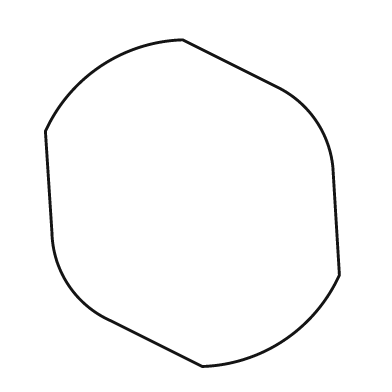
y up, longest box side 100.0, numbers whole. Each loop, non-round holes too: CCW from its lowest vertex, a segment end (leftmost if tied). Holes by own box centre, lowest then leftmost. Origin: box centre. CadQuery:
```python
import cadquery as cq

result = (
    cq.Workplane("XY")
    .moveTo(3.0, -50.0)
    .threePointArc((28.0, -42.0), (45.0, -22.0))
    .lineTo(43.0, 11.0)
    .threePointArc((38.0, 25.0), (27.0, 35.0))
    .lineTo(-3.0, 50.0)
    .threePointArc((-28.0, 42.0), (-45.0, 22.0))
    .lineTo(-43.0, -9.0)
    .threePointArc((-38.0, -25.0), (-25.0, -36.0))
    .close()
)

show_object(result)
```